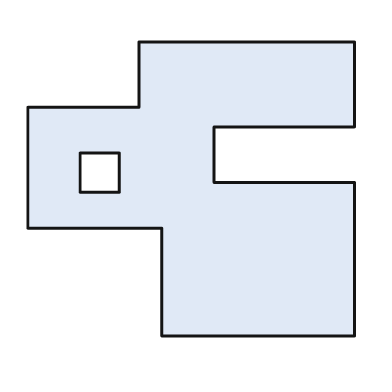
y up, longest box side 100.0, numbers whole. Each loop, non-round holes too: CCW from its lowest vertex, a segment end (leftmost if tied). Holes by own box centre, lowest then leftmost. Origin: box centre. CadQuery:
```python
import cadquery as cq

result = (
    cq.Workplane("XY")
    .moveTo(-9.0, -45.0)
    .lineTo(50.0, -45.0)
    .lineTo(50.0, 2.0)
    .lineTo(7.0, 2.0)
    .lineTo(7.0, 19.0)
    .lineTo(50.0, 19.0)
    .lineTo(50.0, 45.0)
    .lineTo(-16.0, 45.0)
    .lineTo(-16.0, 25.0)
    .lineTo(-50.0, 25.0)
    .lineTo(-50.0, -12.0)
    .lineTo(-9.0, -12.0)
    .close()
    .moveTo(-34.0, -1.0)
    .lineTo(-22.0, -1.0)
    .lineTo(-22.0, 11.0)
    .lineTo(-34.0, 11.0)
    .close()
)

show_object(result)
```